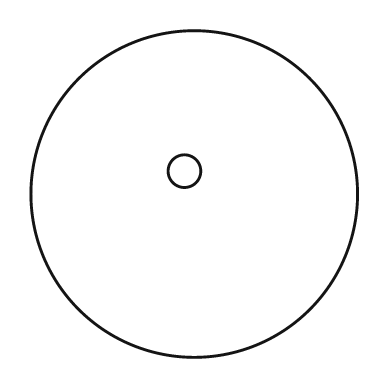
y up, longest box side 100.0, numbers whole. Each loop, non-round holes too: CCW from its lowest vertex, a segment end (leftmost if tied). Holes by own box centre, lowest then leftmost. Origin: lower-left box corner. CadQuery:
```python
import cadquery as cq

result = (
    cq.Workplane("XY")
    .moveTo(50.0, 50.0)
    .circle(50.0)
    .moveTo(47.0, 57.0)
    .circle(5.0)
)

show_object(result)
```